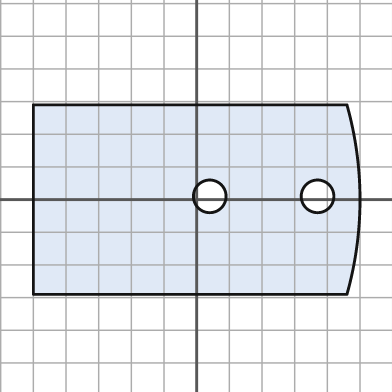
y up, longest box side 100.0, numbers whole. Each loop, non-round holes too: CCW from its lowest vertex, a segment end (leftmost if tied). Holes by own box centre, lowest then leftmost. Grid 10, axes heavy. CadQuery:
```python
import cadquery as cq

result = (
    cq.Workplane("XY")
    .moveTo(-50.0, -29.0)
    .lineTo(46.0, -29.0)
    .threePointArc((50.0, 0.0), (46.0, 29.0))
    .lineTo(-50.0, 29.0)
    .close()
    .moveTo(4.0, 1.0)
    .circle(5.0)
    .moveTo(37.0, 1.0)
    .circle(5.0)
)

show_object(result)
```